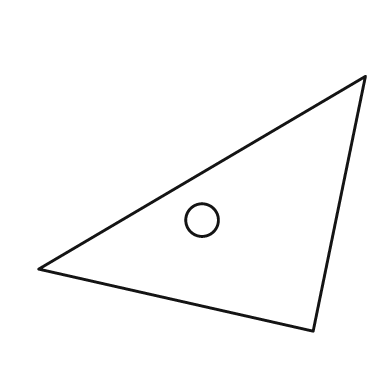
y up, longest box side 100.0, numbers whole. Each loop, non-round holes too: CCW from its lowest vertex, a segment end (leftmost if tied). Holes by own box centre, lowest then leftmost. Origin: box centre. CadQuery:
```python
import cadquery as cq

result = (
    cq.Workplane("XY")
    .moveTo(34.0, -39.0)
    .lineTo(50.0, 39.0)
    .lineTo(-50.0, -20.0)
    .close()
    .moveTo(0.0, -5.0)
    .circle(5.0)
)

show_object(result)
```